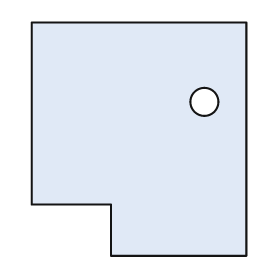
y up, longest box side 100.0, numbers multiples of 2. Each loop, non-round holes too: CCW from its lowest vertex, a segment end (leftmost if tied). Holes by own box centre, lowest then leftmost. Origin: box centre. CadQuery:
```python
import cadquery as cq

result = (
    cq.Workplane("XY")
    .moveTo(-12.0, -50.0)
    .lineTo(46.0, -50.0)
    .lineTo(46.0, 50.0)
    .lineTo(-46.0, 50.0)
    .lineTo(-46.0, -28.0)
    .lineTo(-12.0, -28.0)
    .close()
    .moveTo(28.0, 16.0)
    .circle(6.0)
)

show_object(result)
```